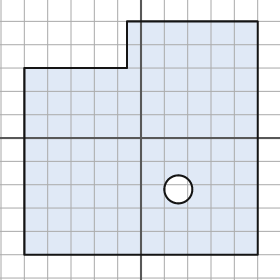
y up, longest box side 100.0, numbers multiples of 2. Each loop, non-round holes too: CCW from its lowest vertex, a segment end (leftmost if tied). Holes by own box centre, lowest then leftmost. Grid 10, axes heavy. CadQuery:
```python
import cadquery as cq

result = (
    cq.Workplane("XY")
    .moveTo(-50.0, -50.0)
    .lineTo(50.0, -50.0)
    .lineTo(50.0, 50.0)
    .lineTo(-6.0, 50.0)
    .lineTo(-6.0, 30.0)
    .lineTo(-50.0, 30.0)
    .close()
    .moveTo(16.0, -22.0)
    .circle(6.0)
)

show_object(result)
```